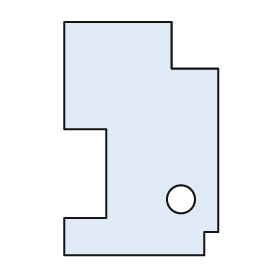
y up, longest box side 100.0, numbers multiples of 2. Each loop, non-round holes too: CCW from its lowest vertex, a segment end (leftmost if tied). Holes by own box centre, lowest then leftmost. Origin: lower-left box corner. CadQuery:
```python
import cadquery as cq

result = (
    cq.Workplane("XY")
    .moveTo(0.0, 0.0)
    .lineTo(60.0, 0.0)
    .lineTo(60.0, 10.0)
    .lineTo(66.0, 10.0)
    .lineTo(66.0, 80.0)
    .lineTo(46.0, 80.0)
    .lineTo(46.0, 100.0)
    .lineTo(0.0, 100.0)
    .lineTo(0.0, 54.0)
    .lineTo(18.0, 54.0)
    .lineTo(18.0, 16.0)
    .lineTo(0.0, 16.0)
    .close()
    .moveTo(50.0, 24.0)
    .circle(6.0)
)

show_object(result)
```